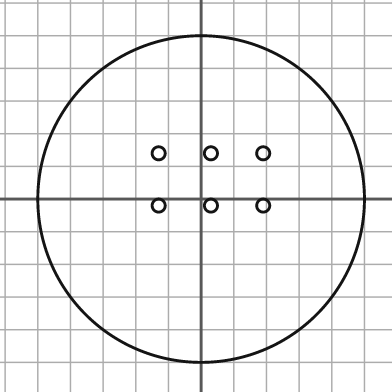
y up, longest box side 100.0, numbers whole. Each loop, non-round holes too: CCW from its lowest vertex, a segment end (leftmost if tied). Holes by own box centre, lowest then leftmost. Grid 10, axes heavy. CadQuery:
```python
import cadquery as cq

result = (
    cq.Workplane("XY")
    .moveTo(0.0, 0.0)
    .circle(50.0)
    .moveTo(-13.0, -2.0)
    .circle(2.0)
    .moveTo(3.0, -2.0)
    .circle(2.0)
    .moveTo(19.0, -2.0)
    .circle(2.0)
    .moveTo(-13.0, 14.0)
    .circle(2.0)
    .moveTo(3.0, 14.0)
    .circle(2.0)
    .moveTo(19.0, 14.0)
    .circle(2.0)
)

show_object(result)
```